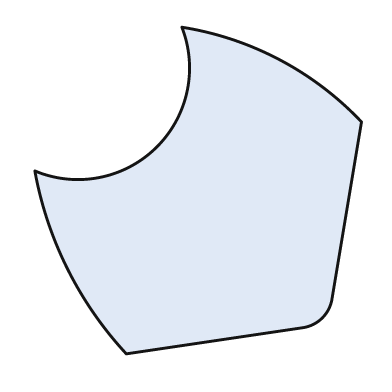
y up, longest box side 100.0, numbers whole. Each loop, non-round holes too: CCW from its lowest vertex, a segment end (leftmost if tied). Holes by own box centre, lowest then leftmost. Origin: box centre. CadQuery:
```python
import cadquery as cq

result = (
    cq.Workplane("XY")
    .moveTo(-22.0, -50.0)
    .lineTo(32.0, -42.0)
    .threePointArc((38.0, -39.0), (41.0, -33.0))
    .lineTo(50.0, 21.0)
    .threePointArc((25.0, 40.0), (-5.0, 50.0))
    .threePointArc((-13.0, 13.0), (-50.0, 6.0))
    .threePointArc((-40.0, -24.0), (-22.0, -50.0))
    .close()
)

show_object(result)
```